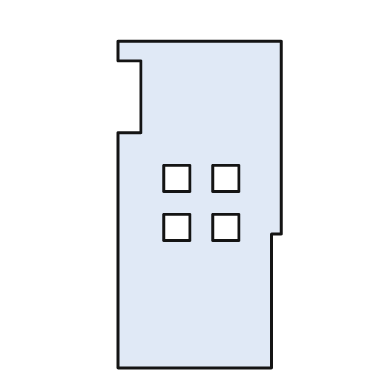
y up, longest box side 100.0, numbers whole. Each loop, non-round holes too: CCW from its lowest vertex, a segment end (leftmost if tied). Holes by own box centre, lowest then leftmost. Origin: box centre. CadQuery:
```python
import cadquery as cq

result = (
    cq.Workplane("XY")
    .moveTo(-25.0, -50.0)
    .lineTo(22.0, -50.0)
    .lineTo(22.0, -9.0)
    .lineTo(25.0, -9.0)
    .lineTo(25.0, 50.0)
    .lineTo(-25.0, 50.0)
    .lineTo(-25.0, 44.0)
    .lineTo(-18.0, 44.0)
    .lineTo(-18.0, 22.0)
    .lineTo(-25.0, 22.0)
    .close()
    .moveTo(-11.0, -11.0)
    .lineTo(-3.0, -11.0)
    .lineTo(-3.0, -3.0)
    .lineTo(-11.0, -3.0)
    .close()
    .moveTo(4.0, -11.0)
    .lineTo(12.0, -11.0)
    .lineTo(12.0, -3.0)
    .lineTo(4.0, -3.0)
    .close()
    .moveTo(-11.0, 4.0)
    .lineTo(-3.0, 4.0)
    .lineTo(-3.0, 12.0)
    .lineTo(-11.0, 12.0)
    .close()
    .moveTo(4.0, 4.0)
    .lineTo(12.0, 4.0)
    .lineTo(12.0, 12.0)
    .lineTo(4.0, 12.0)
    .close()
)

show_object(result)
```